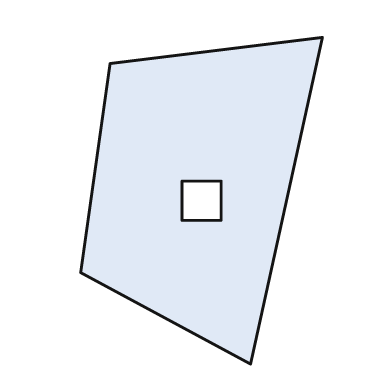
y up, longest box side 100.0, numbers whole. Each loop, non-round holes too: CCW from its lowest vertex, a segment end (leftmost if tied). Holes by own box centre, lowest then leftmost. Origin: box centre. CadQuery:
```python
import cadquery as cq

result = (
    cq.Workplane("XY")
    .moveTo(15.0, -50.0)
    .lineTo(37.0, 50.0)
    .lineTo(-28.0, 42.0)
    .lineTo(-37.0, -22.0)
    .close()
    .moveTo(-6.0, -6.0)
    .lineTo(6.0, -6.0)
    .lineTo(6.0, 6.0)
    .lineTo(-6.0, 6.0)
    .close()
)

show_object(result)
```